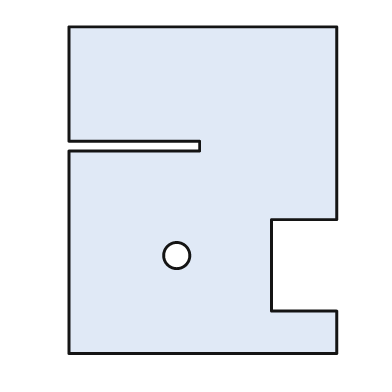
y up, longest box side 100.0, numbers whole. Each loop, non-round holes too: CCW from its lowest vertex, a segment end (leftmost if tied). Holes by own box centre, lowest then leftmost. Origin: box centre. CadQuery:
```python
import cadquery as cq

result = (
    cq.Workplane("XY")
    .moveTo(-41.0, -50.0)
    .lineTo(41.0, -50.0)
    .lineTo(41.0, -37.0)
    .lineTo(21.0, -37.0)
    .lineTo(21.0, -9.0)
    .lineTo(41.0, -9.0)
    .lineTo(41.0, 50.0)
    .lineTo(-41.0, 50.0)
    .lineTo(-41.0, 15.0)
    .lineTo(-1.0, 15.0)
    .lineTo(-1.0, 12.0)
    .lineTo(-41.0, 12.0)
    .close()
    .moveTo(-8.0, -20.0)
    .circle(4.0)
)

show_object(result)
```